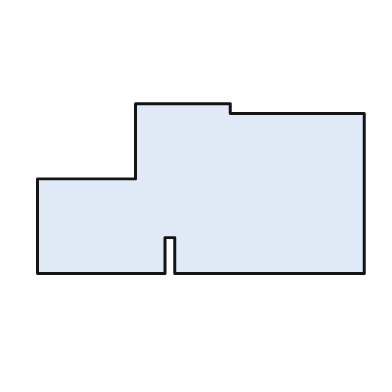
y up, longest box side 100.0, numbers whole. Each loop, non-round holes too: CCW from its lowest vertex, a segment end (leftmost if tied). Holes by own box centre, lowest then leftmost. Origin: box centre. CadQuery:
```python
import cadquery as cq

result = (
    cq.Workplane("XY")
    .moveTo(-50.0, -26.0)
    .lineTo(-11.0, -26.0)
    .lineTo(-11.0, -15.0)
    .lineTo(-8.0, -15.0)
    .lineTo(-8.0, -26.0)
    .lineTo(50.0, -26.0)
    .lineTo(50.0, 23.0)
    .lineTo(9.0, 23.0)
    .lineTo(9.0, 26.0)
    .lineTo(-20.0, 26.0)
    .lineTo(-20.0, 3.0)
    .lineTo(-50.0, 3.0)
    .close()
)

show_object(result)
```